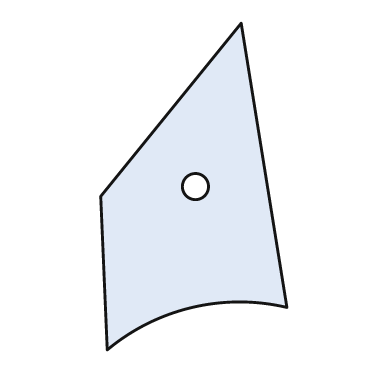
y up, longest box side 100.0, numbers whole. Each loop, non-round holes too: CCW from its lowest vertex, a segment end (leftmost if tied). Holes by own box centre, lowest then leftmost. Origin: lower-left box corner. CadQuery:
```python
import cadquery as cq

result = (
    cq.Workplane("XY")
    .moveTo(2.0, 0.0)
    .threePointArc((28.0, 13.0), (57.0, 13.0))
    .lineTo(43.0, 100.0)
    .lineTo(0.0, 47.0)
    .close()
    .moveTo(29.0, 50.0)
    .circle(4.0)
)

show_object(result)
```